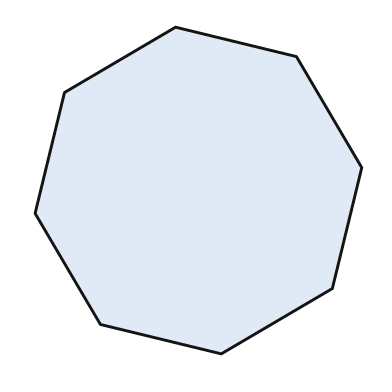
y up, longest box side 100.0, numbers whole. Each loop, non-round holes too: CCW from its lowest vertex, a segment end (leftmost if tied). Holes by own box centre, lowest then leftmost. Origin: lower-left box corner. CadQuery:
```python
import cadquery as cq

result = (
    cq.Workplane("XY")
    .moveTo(57.0, 0.0)
    .lineTo(91.0, 20.0)
    .lineTo(100.0, 57.0)
    .lineTo(80.0, 91.0)
    .lineTo(43.0, 100.0)
    .lineTo(9.0, 80.0)
    .lineTo(0.0, 43.0)
    .lineTo(20.0, 9.0)
    .close()
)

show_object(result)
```